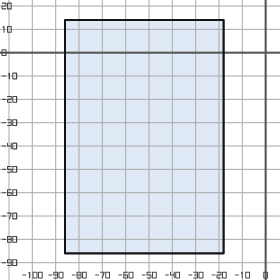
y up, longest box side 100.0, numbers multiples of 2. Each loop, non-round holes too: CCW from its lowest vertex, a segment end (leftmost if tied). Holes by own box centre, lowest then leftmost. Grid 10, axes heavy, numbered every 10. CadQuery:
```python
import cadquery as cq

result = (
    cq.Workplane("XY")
    .moveTo(-86.0, -86.0)
    .lineTo(-18.0, -86.0)
    .lineTo(-18.0, 14.0)
    .lineTo(-86.0, 14.0)
    .close()
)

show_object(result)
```